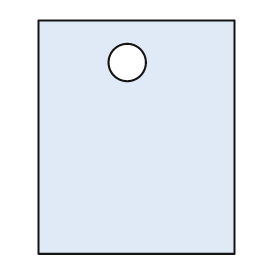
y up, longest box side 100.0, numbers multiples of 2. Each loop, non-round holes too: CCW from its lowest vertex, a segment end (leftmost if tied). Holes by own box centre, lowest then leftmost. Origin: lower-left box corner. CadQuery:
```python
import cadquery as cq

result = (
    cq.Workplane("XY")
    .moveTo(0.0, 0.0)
    .lineTo(84.0, 0.0)
    .lineTo(84.0, 100.0)
    .lineTo(0.0, 100.0)
    .close()
    .moveTo(38.0, 82.0)
    .circle(8.0)
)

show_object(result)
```